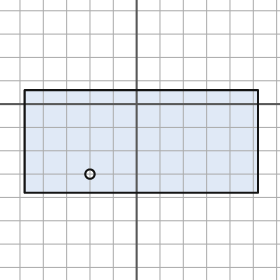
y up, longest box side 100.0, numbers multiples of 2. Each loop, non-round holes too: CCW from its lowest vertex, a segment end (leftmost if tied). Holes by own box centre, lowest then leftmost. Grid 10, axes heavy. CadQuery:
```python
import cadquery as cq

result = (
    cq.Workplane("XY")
    .moveTo(-48.0, -38.0)
    .lineTo(52.0, -38.0)
    .lineTo(52.0, 6.0)
    .lineTo(-48.0, 6.0)
    .close()
    .moveTo(-20.0, -30.0)
    .circle(2.0)
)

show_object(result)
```